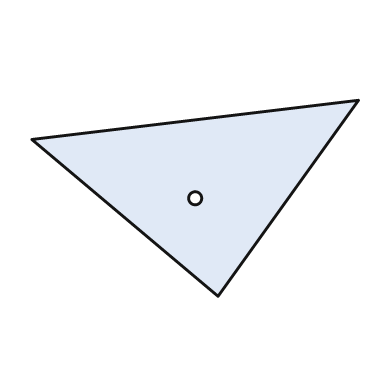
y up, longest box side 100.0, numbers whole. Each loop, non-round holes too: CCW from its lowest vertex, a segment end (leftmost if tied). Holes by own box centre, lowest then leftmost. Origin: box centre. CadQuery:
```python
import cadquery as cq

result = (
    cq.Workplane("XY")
    .moveTo(7.0, -30.0)
    .lineTo(50.0, 30.0)
    .lineTo(-50.0, 18.0)
    .close()
    .moveTo(0.0, 0.0)
    .circle(2.0)
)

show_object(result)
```